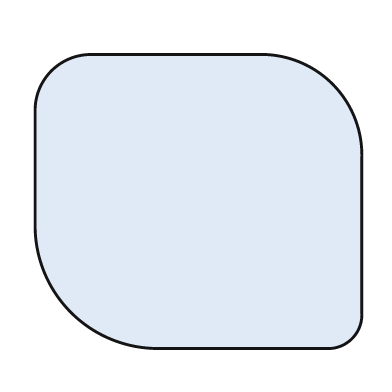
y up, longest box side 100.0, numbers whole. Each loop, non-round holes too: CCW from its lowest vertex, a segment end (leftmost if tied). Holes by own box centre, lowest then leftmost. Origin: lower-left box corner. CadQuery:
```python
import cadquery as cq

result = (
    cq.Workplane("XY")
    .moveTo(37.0, 0.0)
    .lineTo(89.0, 0.0)
    .threePointArc((97.0, 3.0), (100.0, 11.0))
    .lineTo(100.0, 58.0)
    .threePointArc((91.0, 81.0), (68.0, 90.0))
    .lineTo(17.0, 90.0)
    .threePointArc((5.0, 85.0), (0.0, 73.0))
    .lineTo(0.0, 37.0)
    .threePointArc((11.0, 11.0), (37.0, 0.0))
    .close()
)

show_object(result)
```